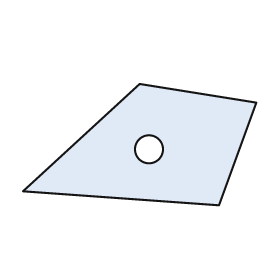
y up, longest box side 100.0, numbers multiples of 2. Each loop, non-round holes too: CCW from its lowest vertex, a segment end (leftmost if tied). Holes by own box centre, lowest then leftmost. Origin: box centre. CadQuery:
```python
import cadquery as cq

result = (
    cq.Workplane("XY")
    .moveTo(34.0, -26.0)
    .lineTo(50.0, 18.0)
    .lineTo(0.0, 26.0)
    .lineTo(-50.0, -20.0)
    .close()
    .moveTo(4.0, -2.0)
    .circle(6.0)
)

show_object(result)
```